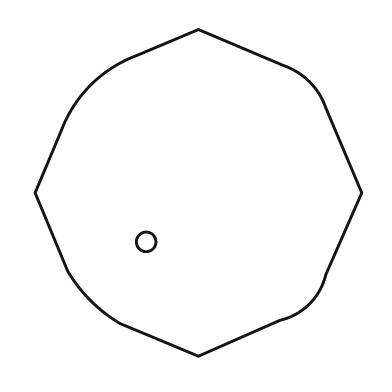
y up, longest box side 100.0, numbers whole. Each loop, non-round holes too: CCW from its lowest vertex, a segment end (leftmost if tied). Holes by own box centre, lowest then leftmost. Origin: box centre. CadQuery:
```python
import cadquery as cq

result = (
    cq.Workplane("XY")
    .moveTo(0.0, -50.0)
    .lineTo(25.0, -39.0)
    .threePointArc((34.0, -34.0), (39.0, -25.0))
    .lineTo(50.0, 0.0)
    .lineTo(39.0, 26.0)
    .threePointArc((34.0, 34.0), (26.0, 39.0))
    .lineTo(0.0, 50.0)
    .lineTo(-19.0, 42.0)
    .threePointArc((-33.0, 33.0), (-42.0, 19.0))
    .lineTo(-50.0, 0.0)
    .lineTo(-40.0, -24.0)
    .threePointArc((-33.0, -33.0), (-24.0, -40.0))
    .close()
    .moveTo(-16.0, -15.0)
    .circle(3.0)
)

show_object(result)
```